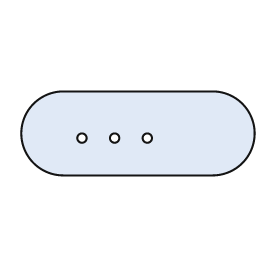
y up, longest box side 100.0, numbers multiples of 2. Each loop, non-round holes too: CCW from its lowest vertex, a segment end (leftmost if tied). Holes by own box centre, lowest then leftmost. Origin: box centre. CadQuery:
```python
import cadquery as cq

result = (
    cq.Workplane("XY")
    .moveTo(-32.0, -18.0)
    .lineTo(32.0, -18.0)
    .threePointArc((50.0, 0.0), (32.0, 18.0))
    .lineTo(-32.0, 18.0)
    .threePointArc((-50.0, 0.0), (-32.0, -18.0))
    .close()
    .moveTo(-24.0, -2.0)
    .circle(2.0)
    .moveTo(-10.0, -2.0)
    .circle(2.0)
    .moveTo(4.0, -2.0)
    .circle(2.0)
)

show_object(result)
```